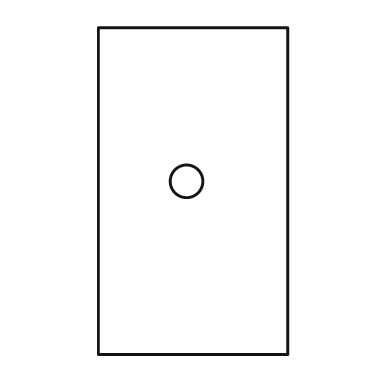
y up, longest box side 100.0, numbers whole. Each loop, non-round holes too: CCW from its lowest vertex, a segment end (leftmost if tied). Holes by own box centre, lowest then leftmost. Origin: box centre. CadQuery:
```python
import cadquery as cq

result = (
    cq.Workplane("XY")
    .moveTo(-29.0, -50.0)
    .lineTo(29.0, -50.0)
    .lineTo(29.0, 50.0)
    .lineTo(-29.0, 50.0)
    .close()
    .moveTo(-2.0, 3.0)
    .circle(5.0)
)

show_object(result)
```